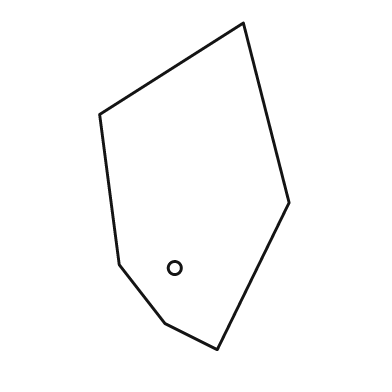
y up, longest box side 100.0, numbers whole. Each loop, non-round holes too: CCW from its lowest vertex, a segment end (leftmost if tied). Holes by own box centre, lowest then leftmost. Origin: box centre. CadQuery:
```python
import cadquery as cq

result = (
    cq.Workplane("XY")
    .moveTo(7.0, -50.0)
    .lineTo(29.0, -5.0)
    .lineTo(15.0, 50.0)
    .lineTo(-29.0, 22.0)
    .lineTo(-23.0, -24.0)
    .lineTo(-9.0, -42.0)
    .close()
    .moveTo(-6.0, -25.0)
    .circle(2.0)
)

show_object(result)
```